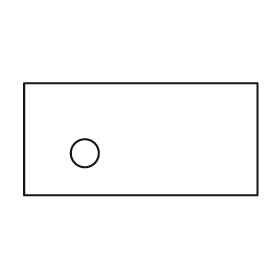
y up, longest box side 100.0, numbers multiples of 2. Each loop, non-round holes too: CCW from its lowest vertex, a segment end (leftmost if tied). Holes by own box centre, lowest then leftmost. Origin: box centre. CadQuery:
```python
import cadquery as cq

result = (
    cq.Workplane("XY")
    .moveTo(-50.0, -24.0)
    .lineTo(50.0, -24.0)
    .lineTo(50.0, 24.0)
    .lineTo(-50.0, 24.0)
    .close()
    .moveTo(-24.0, -6.0)
    .circle(6.0)
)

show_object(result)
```